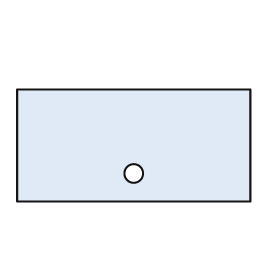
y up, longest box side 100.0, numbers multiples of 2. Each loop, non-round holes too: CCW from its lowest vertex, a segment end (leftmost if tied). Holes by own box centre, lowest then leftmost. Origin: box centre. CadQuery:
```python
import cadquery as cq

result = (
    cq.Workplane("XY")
    .moveTo(-50.0, -24.0)
    .lineTo(50.0, -24.0)
    .lineTo(50.0, 24.0)
    .lineTo(-50.0, 24.0)
    .close()
    .moveTo(0.0, -12.0)
    .circle(4.0)
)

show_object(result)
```